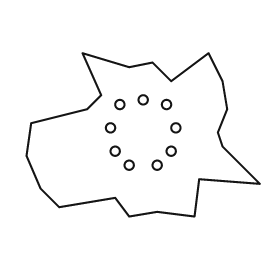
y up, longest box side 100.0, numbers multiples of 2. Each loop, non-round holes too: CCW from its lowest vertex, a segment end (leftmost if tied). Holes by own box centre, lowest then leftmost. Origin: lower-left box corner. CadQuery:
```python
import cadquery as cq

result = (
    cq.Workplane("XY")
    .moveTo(44.0, 0.0)
    .lineTo(56.0, 2.0)
    .lineTo(72.0, 0.0)
    .lineTo(74.0, 16.0)
    .lineTo(100.0, 14.0)
    .lineTo(84.0, 30.0)
    .lineTo(82.0, 36.0)
    .lineTo(86.0, 46.0)
    .lineTo(84.0, 58.0)
    .lineTo(78.0, 70.0)
    .lineTo(62.0, 58.0)
    .lineTo(54.0, 66.0)
    .lineTo(44.0, 64.0)
    .lineTo(24.0, 70.0)
    .lineTo(32.0, 52.0)
    .lineTo(26.0, 46.0)
    .lineTo(2.0, 40.0)
    .lineTo(0.0, 26.0)
    .lineTo(6.0, 12.0)
    .lineTo(14.0, 4.0)
    .lineTo(38.0, 8.0)
    .close()
    .moveTo(44.0, 22.0)
    .circle(2.0)
    .moveTo(56.0, 22.0)
    .circle(2.0)
    .moveTo(38.0, 28.0)
    .circle(2.0)
    .moveTo(62.0, 28.0)
    .circle(2.0)
    .moveTo(36.0, 38.0)
    .circle(2.0)
    .moveTo(64.0, 38.0)
    .circle(2.0)
    .moveTo(40.0, 48.0)
    .circle(2.0)
    .moveTo(60.0, 48.0)
    .circle(2.0)
    .moveTo(50.0, 50.0)
    .circle(2.0)
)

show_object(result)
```